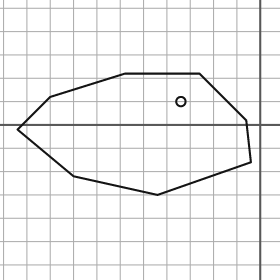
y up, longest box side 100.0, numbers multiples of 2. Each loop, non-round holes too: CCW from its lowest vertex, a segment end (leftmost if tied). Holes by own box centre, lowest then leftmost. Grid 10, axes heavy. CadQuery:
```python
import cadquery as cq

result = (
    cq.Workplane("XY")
    .moveTo(-44.0, -30.0)
    .lineTo(-4.0, -16.0)
    .lineTo(-6.0, 2.0)
    .lineTo(-26.0, 22.0)
    .lineTo(-58.0, 22.0)
    .lineTo(-90.0, 12.0)
    .lineTo(-104.0, -2.0)
    .lineTo(-80.0, -22.0)
    .close()
    .moveTo(-34.0, 10.0)
    .circle(2.0)
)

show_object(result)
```